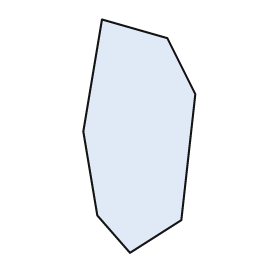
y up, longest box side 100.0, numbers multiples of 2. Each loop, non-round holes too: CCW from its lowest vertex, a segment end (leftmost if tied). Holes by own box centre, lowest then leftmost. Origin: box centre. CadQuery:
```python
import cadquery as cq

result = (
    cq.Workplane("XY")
    .moveTo(-4.0, -50.0)
    .lineTo(18.0, -36.0)
    .lineTo(24.0, 18.0)
    .lineTo(12.0, 42.0)
    .lineTo(-16.0, 50.0)
    .lineTo(-24.0, 2.0)
    .lineTo(-18.0, -34.0)
    .close()
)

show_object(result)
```